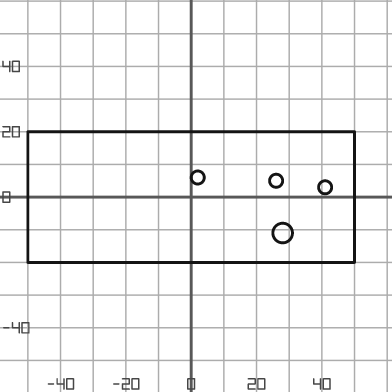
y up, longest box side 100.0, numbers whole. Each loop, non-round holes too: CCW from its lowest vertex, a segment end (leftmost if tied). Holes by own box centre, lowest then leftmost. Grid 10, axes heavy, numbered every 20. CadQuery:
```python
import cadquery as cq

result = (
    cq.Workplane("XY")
    .moveTo(-50.0, -20.0)
    .lineTo(50.0, -20.0)
    .lineTo(50.0, 20.0)
    .lineTo(-50.0, 20.0)
    .close()
    .moveTo(28.0, -11.0)
    .circle(3.0)
    .moveTo(41.0, 3.0)
    .circle(2.0)
    .moveTo(26.0, 5.0)
    .circle(2.0)
    .moveTo(2.0, 6.0)
    .circle(2.0)
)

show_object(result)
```